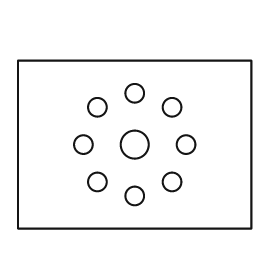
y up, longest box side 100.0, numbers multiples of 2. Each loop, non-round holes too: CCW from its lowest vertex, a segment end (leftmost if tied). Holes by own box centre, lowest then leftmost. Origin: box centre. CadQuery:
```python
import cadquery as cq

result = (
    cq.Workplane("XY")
    .moveTo(-50.0, -36.0)
    .lineTo(50.0, -36.0)
    .lineTo(50.0, 36.0)
    .lineTo(-50.0, 36.0)
    .close()
    .moveTo(0.0, -22.0)
    .circle(4.0)
    .moveTo(-16.0, -16.0)
    .circle(4.0)
    .moveTo(16.0, -16.0)
    .circle(4.0)
    .moveTo(-22.0, 0.0)
    .circle(4.0)
    .moveTo(0.0, 0.0)
    .circle(6.0)
    .moveTo(22.0, 0.0)
    .circle(4.0)
    .moveTo(-16.0, 16.0)
    .circle(4.0)
    .moveTo(16.0, 16.0)
    .circle(4.0)
    .moveTo(0.0, 22.0)
    .circle(4.0)
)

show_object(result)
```